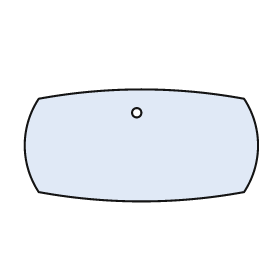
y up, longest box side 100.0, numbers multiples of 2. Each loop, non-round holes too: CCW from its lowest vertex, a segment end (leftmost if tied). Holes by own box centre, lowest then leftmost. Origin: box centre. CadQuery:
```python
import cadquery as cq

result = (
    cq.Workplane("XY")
    .moveTo(-44.0, -20.0)
    .threePointArc((0.0, -24.0), (44.0, -20.0))
    .threePointArc((50.0, 0.0), (44.0, 20.0))
    .threePointArc((0.0, 24.0), (-44.0, 20.0))
    .threePointArc((-50.0, 0.0), (-44.0, -20.0))
    .close()
    .moveTo(-2.0, 14.0)
    .circle(2.0)
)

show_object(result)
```